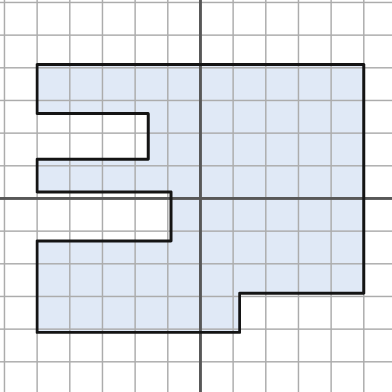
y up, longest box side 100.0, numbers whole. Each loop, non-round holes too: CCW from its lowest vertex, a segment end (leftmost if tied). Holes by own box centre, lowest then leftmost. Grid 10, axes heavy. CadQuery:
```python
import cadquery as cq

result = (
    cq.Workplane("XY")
    .moveTo(-50.0, -41.0)
    .lineTo(12.0, -41.0)
    .lineTo(12.0, -29.0)
    .lineTo(50.0, -29.0)
    .lineTo(50.0, 41.0)
    .lineTo(-50.0, 41.0)
    .lineTo(-50.0, 26.0)
    .lineTo(-16.0, 26.0)
    .lineTo(-16.0, 12.0)
    .lineTo(-50.0, 12.0)
    .lineTo(-50.0, 2.0)
    .lineTo(-9.0, 2.0)
    .lineTo(-9.0, -13.0)
    .lineTo(-50.0, -13.0)
    .close()
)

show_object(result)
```